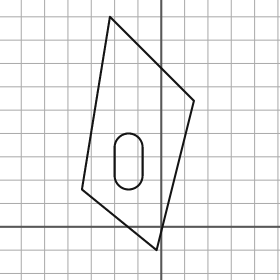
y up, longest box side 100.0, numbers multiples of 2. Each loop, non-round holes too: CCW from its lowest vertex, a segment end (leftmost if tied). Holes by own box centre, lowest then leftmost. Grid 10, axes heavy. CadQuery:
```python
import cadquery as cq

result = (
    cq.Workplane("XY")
    .moveTo(-2.0, -10.0)
    .lineTo(14.0, 54.0)
    .lineTo(-22.0, 90.0)
    .lineTo(-34.0, 16.0)
    .close()
    .moveTo(-20.0, 22.0)
    .threePointArc((-14.0, 16.0), (-8.0, 22.0))
    .lineTo(-8.0, 34.0)
    .threePointArc((-14.0, 40.0), (-20.0, 34.0))
    .close()
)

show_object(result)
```